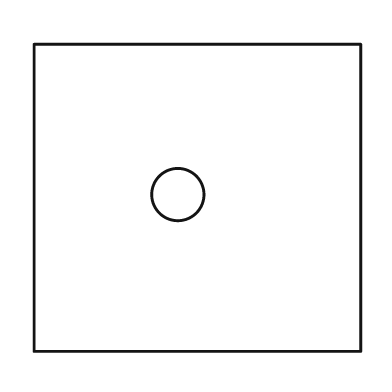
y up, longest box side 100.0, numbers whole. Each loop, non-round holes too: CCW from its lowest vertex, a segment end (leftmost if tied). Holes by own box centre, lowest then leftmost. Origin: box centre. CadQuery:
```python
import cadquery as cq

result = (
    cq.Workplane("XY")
    .moveTo(-50.0, -47.0)
    .lineTo(50.0, -47.0)
    .lineTo(50.0, 47.0)
    .lineTo(-50.0, 47.0)
    .close()
    .moveTo(-6.0, 1.0)
    .circle(8.0)
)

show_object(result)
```